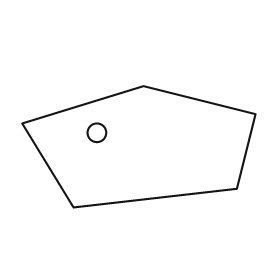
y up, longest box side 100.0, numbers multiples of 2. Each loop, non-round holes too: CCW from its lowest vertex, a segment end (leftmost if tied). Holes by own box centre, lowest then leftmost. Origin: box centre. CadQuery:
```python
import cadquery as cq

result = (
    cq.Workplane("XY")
    .moveTo(-28.0, -26.0)
    .lineTo(42.0, -18.0)
    .lineTo(50.0, 14.0)
    .lineTo(2.0, 26.0)
    .lineTo(-50.0, 10.0)
    .close()
    .moveTo(-18.0, 6.0)
    .circle(4.0)
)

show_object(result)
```